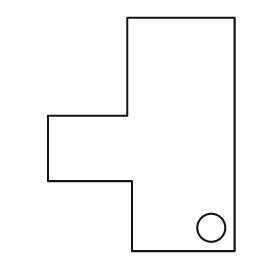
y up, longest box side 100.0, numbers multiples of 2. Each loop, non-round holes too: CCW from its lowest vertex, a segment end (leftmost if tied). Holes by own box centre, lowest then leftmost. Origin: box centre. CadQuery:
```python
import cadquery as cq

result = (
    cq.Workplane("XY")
    .moveTo(-4.0, -50.0)
    .lineTo(40.0, -50.0)
    .lineTo(40.0, 50.0)
    .lineTo(-6.0, 50.0)
    .lineTo(-6.0, 8.0)
    .lineTo(-40.0, 8.0)
    .lineTo(-40.0, -20.0)
    .lineTo(-4.0, -20.0)
    .close()
    .moveTo(30.0, -40.0)
    .circle(6.0)
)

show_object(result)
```